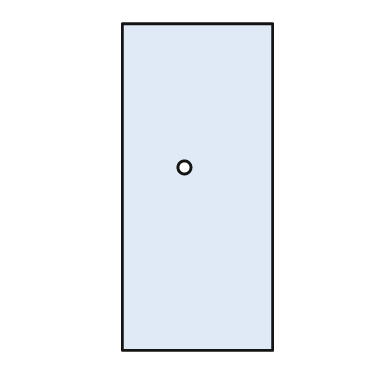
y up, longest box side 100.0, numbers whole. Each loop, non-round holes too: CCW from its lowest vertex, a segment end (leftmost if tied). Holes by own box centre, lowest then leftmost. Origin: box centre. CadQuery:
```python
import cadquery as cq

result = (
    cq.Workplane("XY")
    .moveTo(-23.0, -50.0)
    .lineTo(23.0, -50.0)
    .lineTo(23.0, 50.0)
    .lineTo(-23.0, 50.0)
    .close()
    .moveTo(-4.0, 6.0)
    .circle(2.0)
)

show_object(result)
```